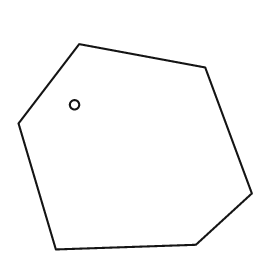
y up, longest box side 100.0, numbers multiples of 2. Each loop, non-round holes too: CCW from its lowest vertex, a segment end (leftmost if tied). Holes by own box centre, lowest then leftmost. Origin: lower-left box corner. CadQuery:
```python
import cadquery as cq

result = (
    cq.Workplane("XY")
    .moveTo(16.0, 0.0)
    .lineTo(76.0, 2.0)
    .lineTo(100.0, 24.0)
    .lineTo(80.0, 78.0)
    .lineTo(26.0, 88.0)
    .lineTo(0.0, 54.0)
    .close()
    .moveTo(24.0, 62.0)
    .circle(2.0)
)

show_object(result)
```